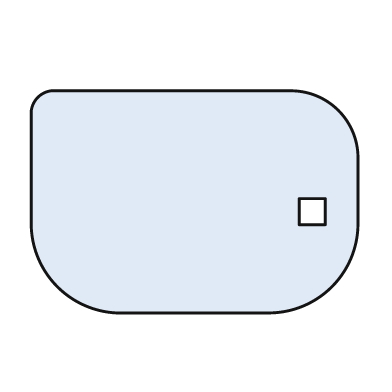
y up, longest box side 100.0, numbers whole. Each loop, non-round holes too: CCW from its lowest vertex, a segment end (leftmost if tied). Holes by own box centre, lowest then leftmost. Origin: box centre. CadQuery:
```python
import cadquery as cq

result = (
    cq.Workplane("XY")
    .moveTo(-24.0, -34.0)
    .lineTo(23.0, -34.0)
    .threePointArc((42.0, -26.0), (50.0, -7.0))
    .lineTo(50.0, 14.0)
    .threePointArc((44.0, 28.0), (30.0, 34.0))
    .lineTo(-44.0, 34.0)
    .threePointArc((-48.0, 32.0), (-50.0, 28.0))
    .lineTo(-50.0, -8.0)
    .threePointArc((-42.0, -26.0), (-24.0, -34.0))
    .close()
    .moveTo(32.0, -7.0)
    .lineTo(40.0, -7.0)
    .lineTo(40.0, 1.0)
    .lineTo(32.0, 1.0)
    .close()
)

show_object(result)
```